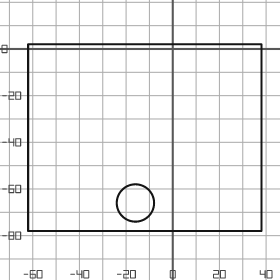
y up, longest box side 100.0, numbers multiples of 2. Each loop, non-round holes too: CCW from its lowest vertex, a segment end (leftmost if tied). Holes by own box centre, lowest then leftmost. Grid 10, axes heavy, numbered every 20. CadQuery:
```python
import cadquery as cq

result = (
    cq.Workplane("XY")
    .moveTo(-62.0, -78.0)
    .lineTo(38.0, -78.0)
    .lineTo(38.0, 2.0)
    .lineTo(-62.0, 2.0)
    .close()
    .moveTo(-16.0, -66.0)
    .circle(8.0)
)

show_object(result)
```